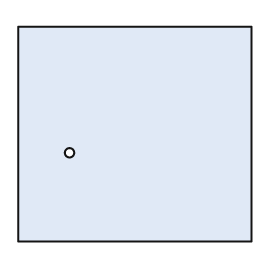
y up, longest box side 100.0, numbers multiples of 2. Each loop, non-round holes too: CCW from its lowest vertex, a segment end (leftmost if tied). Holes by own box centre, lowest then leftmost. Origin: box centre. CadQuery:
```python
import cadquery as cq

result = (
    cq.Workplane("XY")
    .moveTo(-50.0, -46.0)
    .lineTo(50.0, -46.0)
    .lineTo(50.0, 46.0)
    .lineTo(-50.0, 46.0)
    .close()
    .moveTo(-28.0, -8.0)
    .circle(2.0)
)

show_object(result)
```